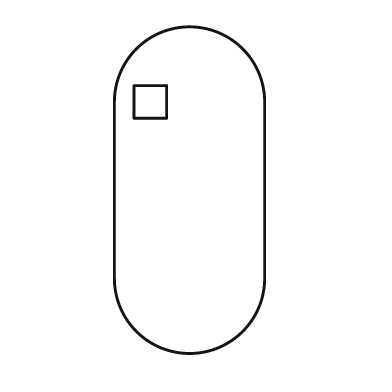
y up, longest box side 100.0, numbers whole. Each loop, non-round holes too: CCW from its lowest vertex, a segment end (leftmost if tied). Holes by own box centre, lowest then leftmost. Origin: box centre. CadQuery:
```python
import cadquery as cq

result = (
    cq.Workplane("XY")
    .moveTo(-23.0, -27.0)
    .threePointArc((0.0, -50.0), (23.0, -27.0))
    .lineTo(23.0, 27.0)
    .threePointArc((0.0, 50.0), (-23.0, 27.0))
    .close()
    .moveTo(-17.0, 22.0)
    .lineTo(-7.0, 22.0)
    .lineTo(-7.0, 32.0)
    .lineTo(-17.0, 32.0)
    .close()
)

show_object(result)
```